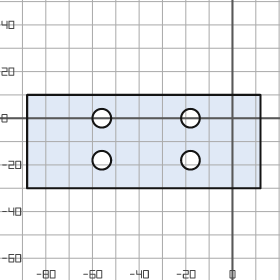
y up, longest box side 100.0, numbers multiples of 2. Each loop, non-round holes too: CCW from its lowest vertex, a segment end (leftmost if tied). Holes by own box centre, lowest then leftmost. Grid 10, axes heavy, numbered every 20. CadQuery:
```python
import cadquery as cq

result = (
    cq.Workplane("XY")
    .moveTo(-88.0, -30.0)
    .lineTo(12.0, -30.0)
    .lineTo(12.0, 10.0)
    .lineTo(-88.0, 10.0)
    .close()
    .moveTo(-56.0, -18.0)
    .circle(4.0)
    .moveTo(-18.0, -18.0)
    .circle(4.0)
    .moveTo(-56.0, 0.0)
    .circle(4.0)
    .moveTo(-18.0, 0.0)
    .circle(4.0)
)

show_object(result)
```